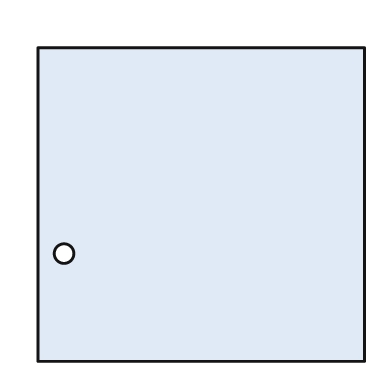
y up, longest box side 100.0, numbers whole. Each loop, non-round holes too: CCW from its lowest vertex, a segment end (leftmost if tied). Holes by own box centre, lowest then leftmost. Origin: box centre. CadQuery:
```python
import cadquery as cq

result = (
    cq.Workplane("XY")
    .moveTo(-50.0, -48.0)
    .lineTo(50.0, -48.0)
    .lineTo(50.0, 48.0)
    .lineTo(-50.0, 48.0)
    .close()
    .moveTo(-42.0, -15.0)
    .circle(3.0)
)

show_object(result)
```